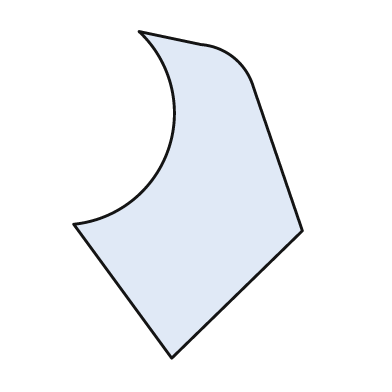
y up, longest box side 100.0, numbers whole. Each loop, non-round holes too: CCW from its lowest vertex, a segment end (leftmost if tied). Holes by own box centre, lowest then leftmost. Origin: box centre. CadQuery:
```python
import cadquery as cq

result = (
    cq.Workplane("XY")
    .moveTo(-5.0, -50.0)
    .lineTo(35.0, -11.0)
    .lineTo(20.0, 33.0)
    .threePointArc((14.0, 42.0), (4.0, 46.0))
    .lineTo(-15.0, 50.0)
    .threePointArc((-6.0, 14.0), (-35.0, -9.0))
    .close()
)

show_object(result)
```